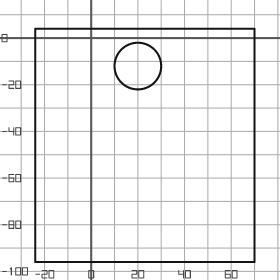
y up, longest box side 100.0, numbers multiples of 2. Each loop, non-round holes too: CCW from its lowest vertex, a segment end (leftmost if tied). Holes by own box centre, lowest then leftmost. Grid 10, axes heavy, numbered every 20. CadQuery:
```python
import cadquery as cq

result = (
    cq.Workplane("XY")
    .moveTo(-24.0, -96.0)
    .lineTo(70.0, -96.0)
    .lineTo(70.0, 4.0)
    .lineTo(-24.0, 4.0)
    .close()
    .moveTo(20.0, -12.0)
    .circle(10.0)
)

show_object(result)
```